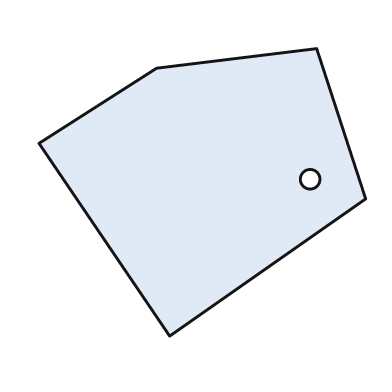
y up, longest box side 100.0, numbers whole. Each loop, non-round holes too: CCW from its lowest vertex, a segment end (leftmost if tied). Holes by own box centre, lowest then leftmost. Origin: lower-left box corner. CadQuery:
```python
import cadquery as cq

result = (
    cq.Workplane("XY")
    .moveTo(40.0, 0.0)
    .lineTo(100.0, 42.0)
    .lineTo(85.0, 88.0)
    .lineTo(36.0, 82.0)
    .lineTo(0.0, 59.0)
    .close()
    .moveTo(83.0, 48.0)
    .circle(3.0)
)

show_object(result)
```